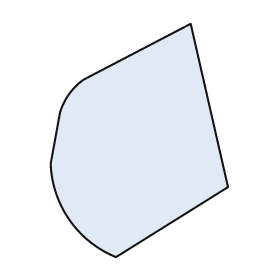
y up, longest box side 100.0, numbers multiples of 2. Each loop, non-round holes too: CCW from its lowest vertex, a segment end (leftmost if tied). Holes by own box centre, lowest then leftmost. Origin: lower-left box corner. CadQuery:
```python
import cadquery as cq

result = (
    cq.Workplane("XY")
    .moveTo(28.0, 0.0)
    .lineTo(76.0, 30.0)
    .lineTo(60.0, 100.0)
    .lineTo(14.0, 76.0)
    .threePointArc((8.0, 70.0), (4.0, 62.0))
    .lineTo(0.0, 40.0)
    .threePointArc((8.0, 16.0), (28.0, 0.0))
    .close()
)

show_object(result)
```